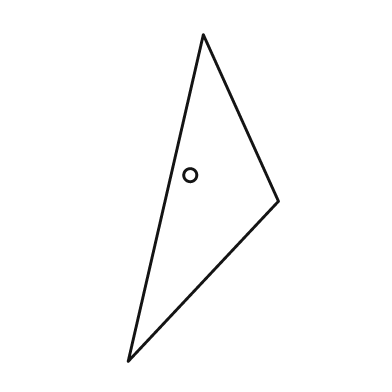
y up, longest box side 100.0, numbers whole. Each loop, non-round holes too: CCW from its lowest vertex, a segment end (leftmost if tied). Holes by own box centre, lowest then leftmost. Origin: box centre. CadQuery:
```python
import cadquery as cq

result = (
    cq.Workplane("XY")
    .moveTo(-23.0, -50.0)
    .lineTo(23.0, -1.0)
    .lineTo(0.0, 50.0)
    .close()
    .moveTo(-4.0, 7.0)
    .circle(2.0)
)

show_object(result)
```